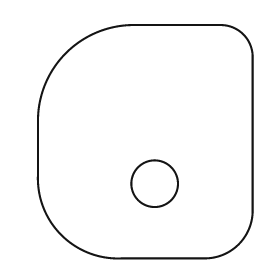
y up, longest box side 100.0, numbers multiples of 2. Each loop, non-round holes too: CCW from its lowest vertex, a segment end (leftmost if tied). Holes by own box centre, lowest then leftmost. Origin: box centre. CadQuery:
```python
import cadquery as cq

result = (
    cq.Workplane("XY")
    .moveTo(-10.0, -50.0)
    .lineTo(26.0, -50.0)
    .threePointArc((40.0, -44.0), (46.0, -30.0))
    .lineTo(46.0, 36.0)
    .threePointArc((42.0, 46.0), (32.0, 50.0))
    .lineTo(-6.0, 50.0)
    .threePointArc((-34.0, 38.0), (-46.0, 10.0))
    .lineTo(-46.0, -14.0)
    .threePointArc((-36.0, -40.0), (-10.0, -50.0))
    .close()
    .moveTo(4.0, -18.0)
    .circle(10.0)
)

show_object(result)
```